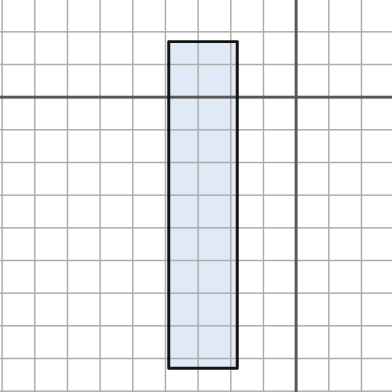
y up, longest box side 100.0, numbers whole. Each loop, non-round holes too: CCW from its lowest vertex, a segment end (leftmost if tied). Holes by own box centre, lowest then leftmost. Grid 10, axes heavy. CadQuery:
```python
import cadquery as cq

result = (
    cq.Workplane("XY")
    .moveTo(-39.0, -83.0)
    .lineTo(-18.0, -83.0)
    .lineTo(-18.0, 17.0)
    .lineTo(-39.0, 17.0)
    .close()
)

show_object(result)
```